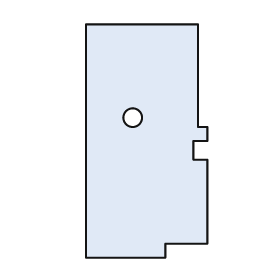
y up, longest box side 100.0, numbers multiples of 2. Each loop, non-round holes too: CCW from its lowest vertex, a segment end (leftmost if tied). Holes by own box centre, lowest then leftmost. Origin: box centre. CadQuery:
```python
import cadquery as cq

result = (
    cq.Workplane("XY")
    .moveTo(-26.0, -50.0)
    .lineTo(8.0, -50.0)
    .lineTo(8.0, -44.0)
    .lineTo(26.0, -44.0)
    .lineTo(26.0, -8.0)
    .lineTo(20.0, -8.0)
    .lineTo(20.0, 0.0)
    .lineTo(26.0, 0.0)
    .lineTo(26.0, 6.0)
    .lineTo(22.0, 6.0)
    .lineTo(22.0, 50.0)
    .lineTo(-26.0, 50.0)
    .close()
    .moveTo(-6.0, 10.0)
    .circle(4.0)
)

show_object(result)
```